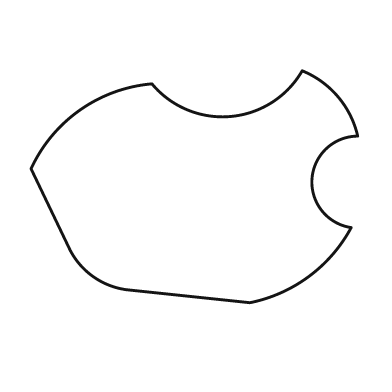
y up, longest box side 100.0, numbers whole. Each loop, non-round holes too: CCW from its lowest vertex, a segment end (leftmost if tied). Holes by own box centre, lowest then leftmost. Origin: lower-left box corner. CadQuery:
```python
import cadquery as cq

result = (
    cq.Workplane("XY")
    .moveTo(67.0, 0.0)
    .threePointArc((85.0, 8.0), (98.0, 23.0))
    .threePointArc((86.0, 38.0), (100.0, 51.0))
    .threePointArc((94.0, 63.0), (83.0, 71.0))
    .threePointArc((61.0, 57.0), (37.0, 67.0))
    .threePointArc((15.0, 59.0), (0.0, 41.0))
    .lineTo(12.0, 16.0)
    .threePointArc((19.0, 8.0), (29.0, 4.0))
    .close()
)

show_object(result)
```